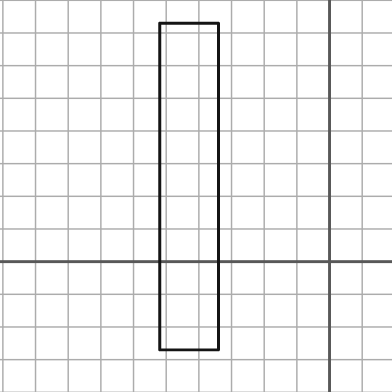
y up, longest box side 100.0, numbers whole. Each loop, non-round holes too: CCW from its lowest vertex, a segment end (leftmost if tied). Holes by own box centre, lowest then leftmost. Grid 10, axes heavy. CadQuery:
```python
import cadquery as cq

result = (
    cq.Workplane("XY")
    .moveTo(-52.0, -27.0)
    .lineTo(-34.0, -27.0)
    .lineTo(-34.0, 73.0)
    .lineTo(-52.0, 73.0)
    .close()
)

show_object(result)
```